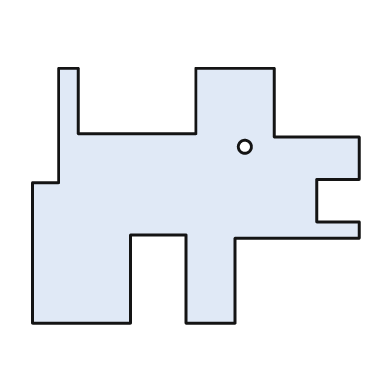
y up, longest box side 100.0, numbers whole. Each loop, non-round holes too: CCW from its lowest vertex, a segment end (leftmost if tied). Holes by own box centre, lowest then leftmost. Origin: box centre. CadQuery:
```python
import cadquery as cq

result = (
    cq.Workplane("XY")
    .moveTo(-50.0, -39.0)
    .lineTo(-20.0, -39.0)
    .lineTo(-20.0, -12.0)
    .lineTo(-3.0, -12.0)
    .lineTo(-3.0, -39.0)
    .lineTo(12.0, -39.0)
    .lineTo(12.0, -13.0)
    .lineTo(50.0, -13.0)
    .lineTo(50.0, -8.0)
    .lineTo(37.0, -8.0)
    .lineTo(37.0, 5.0)
    .lineTo(50.0, 5.0)
    .lineTo(50.0, 18.0)
    .lineTo(24.0, 18.0)
    .lineTo(24.0, 39.0)
    .lineTo(0.0, 39.0)
    .lineTo(0.0, 19.0)
    .lineTo(-36.0, 19.0)
    .lineTo(-36.0, 39.0)
    .lineTo(-42.0, 39.0)
    .lineTo(-42.0, 4.0)
    .lineTo(-50.0, 4.0)
    .close()
    .moveTo(15.0, 15.0)
    .circle(2.0)
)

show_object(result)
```